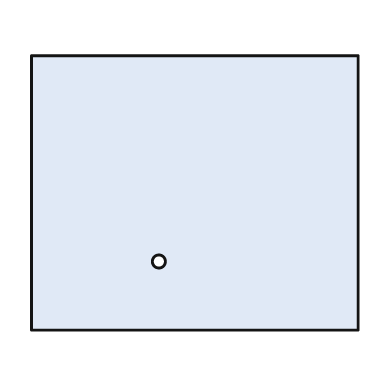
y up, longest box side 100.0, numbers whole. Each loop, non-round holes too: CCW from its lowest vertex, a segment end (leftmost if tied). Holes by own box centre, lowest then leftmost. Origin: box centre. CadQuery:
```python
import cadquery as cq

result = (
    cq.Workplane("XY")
    .moveTo(-50.0, -42.0)
    .lineTo(50.0, -42.0)
    .lineTo(50.0, 42.0)
    .lineTo(-50.0, 42.0)
    .close()
    .moveTo(-11.0, -21.0)
    .circle(2.0)
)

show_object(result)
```